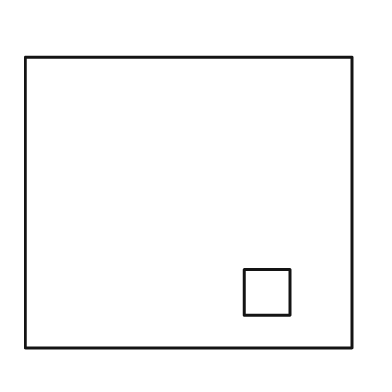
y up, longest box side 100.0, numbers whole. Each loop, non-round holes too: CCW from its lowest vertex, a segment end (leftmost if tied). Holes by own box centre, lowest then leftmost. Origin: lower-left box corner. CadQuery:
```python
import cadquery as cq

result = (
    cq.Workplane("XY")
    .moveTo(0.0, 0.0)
    .lineTo(100.0, 0.0)
    .lineTo(100.0, 89.0)
    .lineTo(0.0, 89.0)
    .close()
    .moveTo(67.0, 10.0)
    .lineTo(81.0, 10.0)
    .lineTo(81.0, 24.0)
    .lineTo(67.0, 24.0)
    .close()
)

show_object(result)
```